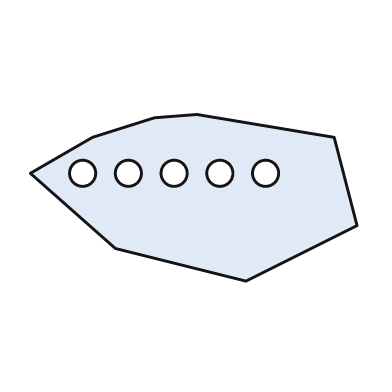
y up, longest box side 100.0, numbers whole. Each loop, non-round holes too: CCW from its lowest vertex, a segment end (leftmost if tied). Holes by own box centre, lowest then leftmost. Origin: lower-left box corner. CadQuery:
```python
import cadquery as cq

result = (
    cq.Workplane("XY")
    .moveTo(66.0, 0.0)
    .lineTo(100.0, 17.0)
    .lineTo(93.0, 44.0)
    .lineTo(51.0, 51.0)
    .lineTo(38.0, 50.0)
    .lineTo(19.0, 44.0)
    .lineTo(0.0, 33.0)
    .lineTo(26.0, 10.0)
    .close()
    .moveTo(16.0, 33.0)
    .circle(4.0)
    .moveTo(30.0, 33.0)
    .circle(4.0)
    .moveTo(44.0, 33.0)
    .circle(4.0)
    .moveTo(58.0, 33.0)
    .circle(4.0)
    .moveTo(72.0, 33.0)
    .circle(4.0)
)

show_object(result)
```